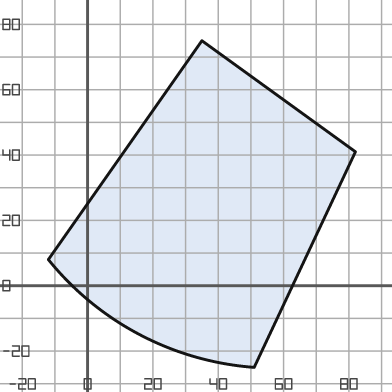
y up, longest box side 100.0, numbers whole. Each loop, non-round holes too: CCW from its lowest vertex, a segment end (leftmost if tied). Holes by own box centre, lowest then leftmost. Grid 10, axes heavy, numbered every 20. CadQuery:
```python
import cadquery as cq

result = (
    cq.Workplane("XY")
    .moveTo(51.0, -25.0)
    .lineTo(82.0, 41.0)
    .lineTo(35.0, 75.0)
    .lineTo(-12.0, 8.0)
    .threePointArc((16.0, -15.0), (51.0, -25.0))
    .close()
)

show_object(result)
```